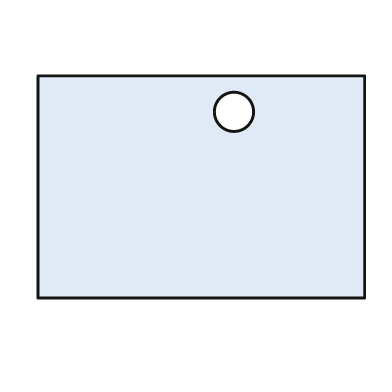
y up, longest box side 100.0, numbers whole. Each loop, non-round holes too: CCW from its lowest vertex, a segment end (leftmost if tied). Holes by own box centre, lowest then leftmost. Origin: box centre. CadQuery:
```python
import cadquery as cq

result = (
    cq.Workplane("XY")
    .moveTo(-50.0, -34.0)
    .lineTo(50.0, -34.0)
    .lineTo(50.0, 34.0)
    .lineTo(-50.0, 34.0)
    .close()
    .moveTo(10.0, 23.0)
    .circle(6.0)
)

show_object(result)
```